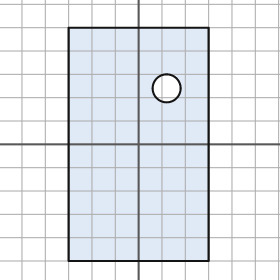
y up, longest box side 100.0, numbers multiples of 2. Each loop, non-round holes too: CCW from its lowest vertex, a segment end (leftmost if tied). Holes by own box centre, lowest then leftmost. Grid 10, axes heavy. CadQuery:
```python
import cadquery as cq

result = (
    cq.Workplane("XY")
    .moveTo(-30.0, -50.0)
    .lineTo(30.0, -50.0)
    .lineTo(30.0, 50.0)
    .lineTo(-30.0, 50.0)
    .close()
    .moveTo(12.0, 24.0)
    .circle(6.0)
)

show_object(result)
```